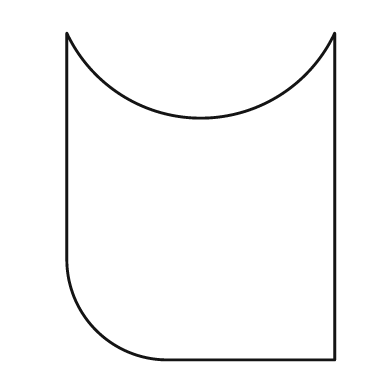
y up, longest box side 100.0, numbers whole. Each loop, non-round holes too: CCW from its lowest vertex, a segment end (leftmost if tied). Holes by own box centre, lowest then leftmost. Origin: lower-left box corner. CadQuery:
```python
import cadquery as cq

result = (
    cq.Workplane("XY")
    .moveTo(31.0, 0.0)
    .lineTo(82.0, 0.0)
    .lineTo(82.0, 100.0)
    .threePointArc((41.0, 74.0), (0.0, 100.0))
    .lineTo(0.0, 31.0)
    .threePointArc((9.0, 9.0), (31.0, 0.0))
    .close()
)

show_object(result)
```